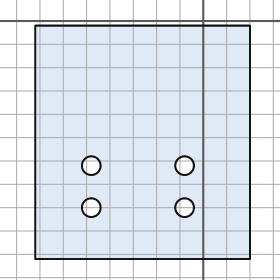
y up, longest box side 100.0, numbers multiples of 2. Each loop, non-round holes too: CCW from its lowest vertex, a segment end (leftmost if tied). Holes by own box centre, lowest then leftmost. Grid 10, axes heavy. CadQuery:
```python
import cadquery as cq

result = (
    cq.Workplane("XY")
    .moveTo(-72.0, -102.0)
    .lineTo(20.0, -102.0)
    .lineTo(20.0, -2.0)
    .lineTo(-72.0, -2.0)
    .close()
    .moveTo(-48.0, -80.0)
    .circle(4.0)
    .moveTo(-8.0, -80.0)
    .circle(4.0)
    .moveTo(-48.0, -62.0)
    .circle(4.0)
    .moveTo(-8.0, -62.0)
    .circle(4.0)
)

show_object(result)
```